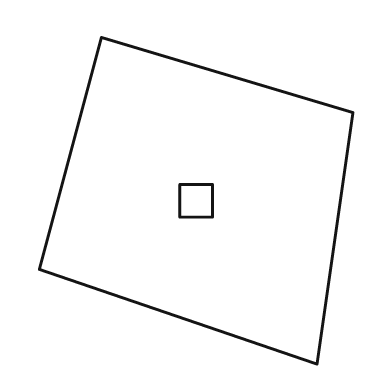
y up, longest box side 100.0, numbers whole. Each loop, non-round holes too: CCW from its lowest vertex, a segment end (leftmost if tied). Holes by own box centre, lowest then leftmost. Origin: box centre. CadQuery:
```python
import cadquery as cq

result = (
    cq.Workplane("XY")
    .moveTo(37.0, -50.0)
    .lineTo(48.0, 27.0)
    .lineTo(-29.0, 50.0)
    .lineTo(-48.0, -21.0)
    .close()
    .moveTo(-5.0, -5.0)
    .lineTo(5.0, -5.0)
    .lineTo(5.0, 5.0)
    .lineTo(-5.0, 5.0)
    .close()
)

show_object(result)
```